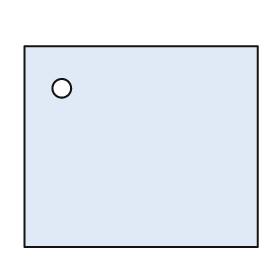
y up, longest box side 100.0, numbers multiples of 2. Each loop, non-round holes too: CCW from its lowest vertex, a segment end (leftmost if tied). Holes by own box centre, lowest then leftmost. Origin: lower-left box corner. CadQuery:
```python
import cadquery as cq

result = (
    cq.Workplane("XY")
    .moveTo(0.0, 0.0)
    .lineTo(100.0, 0.0)
    .lineTo(100.0, 86.0)
    .lineTo(0.0, 86.0)
    .close()
    .moveTo(16.0, 68.0)
    .circle(4.0)
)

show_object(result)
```